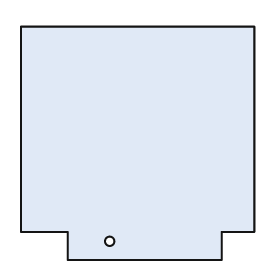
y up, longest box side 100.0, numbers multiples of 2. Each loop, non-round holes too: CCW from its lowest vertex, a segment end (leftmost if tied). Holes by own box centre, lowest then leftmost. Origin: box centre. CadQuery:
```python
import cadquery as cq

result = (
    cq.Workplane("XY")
    .moveTo(-30.0, -50.0)
    .lineTo(36.0, -50.0)
    .lineTo(36.0, -38.0)
    .lineTo(50.0, -38.0)
    .lineTo(50.0, 50.0)
    .lineTo(-50.0, 50.0)
    .lineTo(-50.0, -38.0)
    .lineTo(-30.0, -38.0)
    .close()
    .moveTo(-12.0, -42.0)
    .circle(2.0)
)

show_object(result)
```